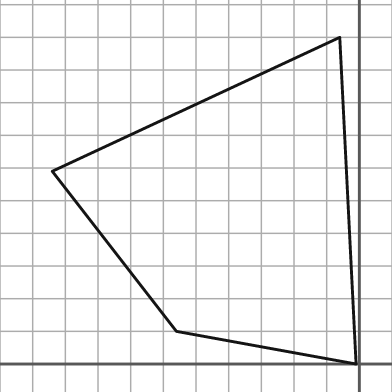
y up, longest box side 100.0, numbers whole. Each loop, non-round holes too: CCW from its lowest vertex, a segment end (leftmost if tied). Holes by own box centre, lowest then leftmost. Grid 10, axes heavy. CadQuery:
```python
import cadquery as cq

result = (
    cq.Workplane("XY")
    .moveTo(-1.0, 0.0)
    .lineTo(-6.0, 100.0)
    .lineTo(-94.0, 59.0)
    .lineTo(-56.0, 10.0)
    .close()
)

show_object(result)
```